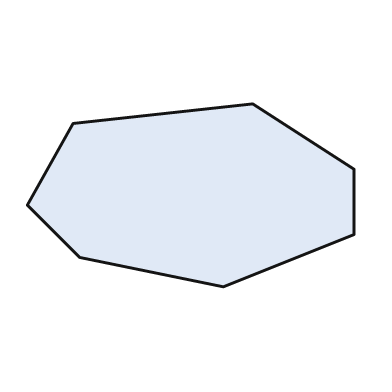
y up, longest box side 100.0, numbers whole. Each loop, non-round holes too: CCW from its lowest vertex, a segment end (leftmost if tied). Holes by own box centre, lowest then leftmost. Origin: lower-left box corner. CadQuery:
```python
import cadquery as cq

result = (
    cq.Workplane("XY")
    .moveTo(60.0, 0.0)
    .lineTo(100.0, 16.0)
    .lineTo(100.0, 36.0)
    .lineTo(69.0, 56.0)
    .lineTo(14.0, 50.0)
    .lineTo(0.0, 25.0)
    .lineTo(16.0, 9.0)
    .close()
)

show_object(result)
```